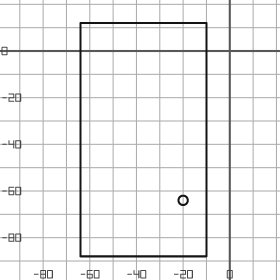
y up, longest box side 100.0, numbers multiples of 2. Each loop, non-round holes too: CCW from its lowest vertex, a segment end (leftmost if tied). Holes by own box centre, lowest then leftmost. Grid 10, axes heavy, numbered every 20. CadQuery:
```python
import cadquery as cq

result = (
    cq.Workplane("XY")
    .moveTo(-64.0, -88.0)
    .lineTo(-10.0, -88.0)
    .lineTo(-10.0, 12.0)
    .lineTo(-64.0, 12.0)
    .close()
    .moveTo(-20.0, -64.0)
    .circle(2.0)
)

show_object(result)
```